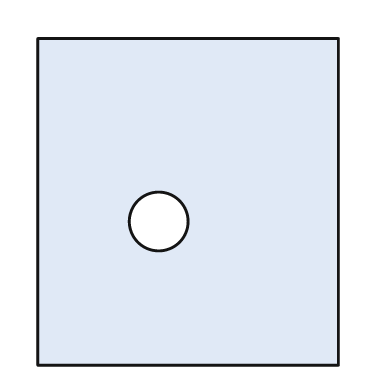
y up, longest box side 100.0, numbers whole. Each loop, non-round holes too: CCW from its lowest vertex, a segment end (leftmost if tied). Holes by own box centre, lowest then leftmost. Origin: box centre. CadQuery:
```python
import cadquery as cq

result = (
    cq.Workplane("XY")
    .moveTo(-46.0, -50.0)
    .lineTo(46.0, -50.0)
    .lineTo(46.0, 50.0)
    .lineTo(-46.0, 50.0)
    .close()
    .moveTo(-9.0, -6.0)
    .circle(9.0)
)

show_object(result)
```